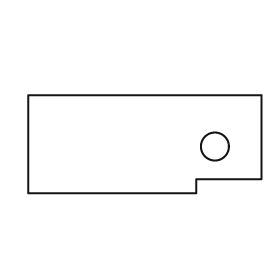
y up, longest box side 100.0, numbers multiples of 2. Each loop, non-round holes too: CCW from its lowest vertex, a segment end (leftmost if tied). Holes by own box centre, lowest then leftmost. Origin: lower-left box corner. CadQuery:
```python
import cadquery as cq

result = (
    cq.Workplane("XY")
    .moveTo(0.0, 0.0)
    .lineTo(72.0, 0.0)
    .lineTo(72.0, 6.0)
    .lineTo(100.0, 6.0)
    .lineTo(100.0, 42.0)
    .lineTo(0.0, 42.0)
    .close()
    .moveTo(80.0, 20.0)
    .circle(6.0)
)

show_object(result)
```